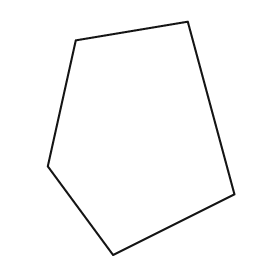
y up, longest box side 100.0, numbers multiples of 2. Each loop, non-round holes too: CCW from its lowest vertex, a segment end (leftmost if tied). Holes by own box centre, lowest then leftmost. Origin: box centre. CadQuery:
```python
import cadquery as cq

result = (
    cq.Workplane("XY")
    .moveTo(-12.0, -50.0)
    .lineTo(40.0, -24.0)
    .lineTo(20.0, 50.0)
    .lineTo(-28.0, 42.0)
    .lineTo(-40.0, -12.0)
    .close()
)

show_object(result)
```